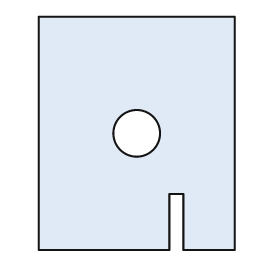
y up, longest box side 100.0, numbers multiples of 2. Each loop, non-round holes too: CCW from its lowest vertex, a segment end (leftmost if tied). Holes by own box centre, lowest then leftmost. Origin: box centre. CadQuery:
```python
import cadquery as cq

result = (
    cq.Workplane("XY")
    .moveTo(-42.0, -50.0)
    .lineTo(14.0, -50.0)
    .lineTo(14.0, -26.0)
    .lineTo(20.0, -26.0)
    .lineTo(20.0, -50.0)
    .lineTo(42.0, -50.0)
    .lineTo(42.0, 50.0)
    .lineTo(-42.0, 50.0)
    .close()
    .moveTo(0.0, 0.0)
    .circle(10.0)
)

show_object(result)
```